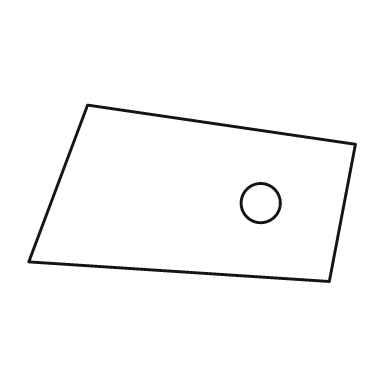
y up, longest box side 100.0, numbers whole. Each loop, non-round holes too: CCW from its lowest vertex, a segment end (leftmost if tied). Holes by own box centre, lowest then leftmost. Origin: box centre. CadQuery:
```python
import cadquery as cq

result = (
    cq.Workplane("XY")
    .moveTo(42.0, -27.0)
    .lineTo(50.0, 15.0)
    .lineTo(-32.0, 27.0)
    .lineTo(-50.0, -21.0)
    .close()
    .moveTo(21.0, -3.0)
    .circle(6.0)
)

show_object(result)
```